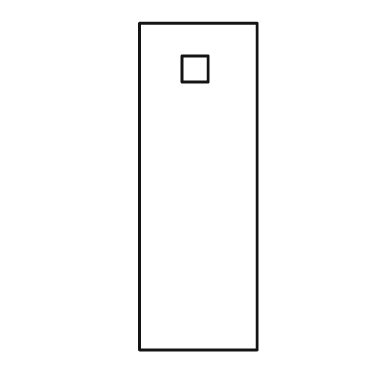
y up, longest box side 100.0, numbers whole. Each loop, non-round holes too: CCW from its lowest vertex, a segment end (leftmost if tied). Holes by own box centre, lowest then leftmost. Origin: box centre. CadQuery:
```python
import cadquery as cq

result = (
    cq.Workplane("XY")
    .moveTo(-18.0, -50.0)
    .lineTo(18.0, -50.0)
    .lineTo(18.0, 50.0)
    .lineTo(-18.0, 50.0)
    .close()
    .moveTo(-5.0, 32.0)
    .lineTo(3.0, 32.0)
    .lineTo(3.0, 40.0)
    .lineTo(-5.0, 40.0)
    .close()
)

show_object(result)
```